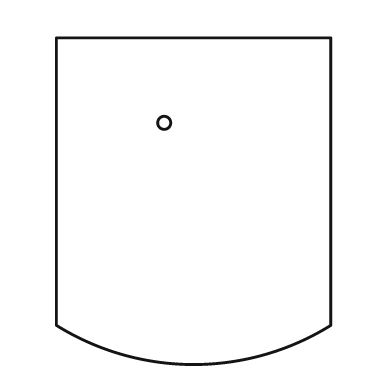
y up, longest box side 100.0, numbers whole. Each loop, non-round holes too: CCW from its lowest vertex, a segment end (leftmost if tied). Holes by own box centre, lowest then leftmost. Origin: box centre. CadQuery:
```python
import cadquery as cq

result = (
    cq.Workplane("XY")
    .moveTo(-42.0, -38.0)
    .threePointArc((0.0, -50.0), (42.0, -38.0))
    .lineTo(42.0, 50.0)
    .lineTo(-42.0, 50.0)
    .close()
    .moveTo(-9.0, 24.0)
    .circle(2.0)
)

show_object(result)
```